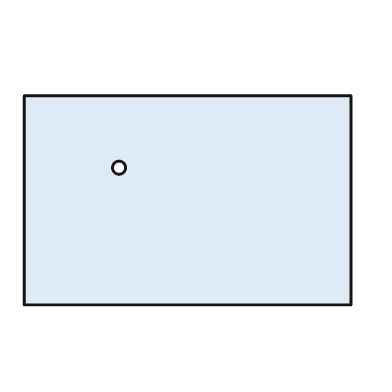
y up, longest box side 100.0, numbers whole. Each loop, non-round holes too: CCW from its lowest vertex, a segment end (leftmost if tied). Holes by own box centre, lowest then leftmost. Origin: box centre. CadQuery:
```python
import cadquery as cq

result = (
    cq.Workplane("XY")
    .moveTo(-50.0, -32.0)
    .lineTo(50.0, -32.0)
    .lineTo(50.0, 32.0)
    .lineTo(-50.0, 32.0)
    .close()
    .moveTo(-21.0, 10.0)
    .circle(2.0)
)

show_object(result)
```